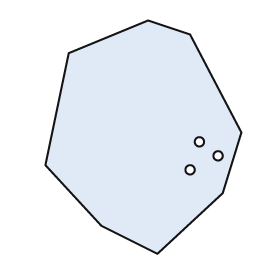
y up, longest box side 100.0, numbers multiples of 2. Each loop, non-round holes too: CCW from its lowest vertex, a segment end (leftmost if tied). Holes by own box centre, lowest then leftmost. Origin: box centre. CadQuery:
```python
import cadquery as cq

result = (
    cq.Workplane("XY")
    .moveTo(6.0, -50.0)
    .lineTo(34.0, -24.0)
    .lineTo(42.0, 2.0)
    .lineTo(20.0, 44.0)
    .lineTo(2.0, 50.0)
    .lineTo(-32.0, 36.0)
    .lineTo(-42.0, -12.0)
    .lineTo(-18.0, -38.0)
    .close()
    .moveTo(20.0, -14.0)
    .circle(2.0)
    .moveTo(32.0, -8.0)
    .circle(2.0)
    .moveTo(24.0, -2.0)
    .circle(2.0)
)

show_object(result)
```